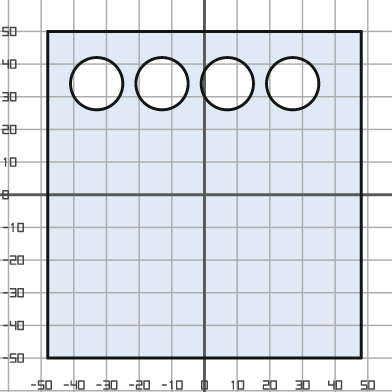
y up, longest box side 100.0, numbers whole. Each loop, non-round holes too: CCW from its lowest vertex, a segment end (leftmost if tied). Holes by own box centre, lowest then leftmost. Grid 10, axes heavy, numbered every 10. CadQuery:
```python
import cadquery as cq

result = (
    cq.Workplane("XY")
    .moveTo(-48.0, -50.0)
    .lineTo(48.0, -50.0)
    .lineTo(48.0, 50.0)
    .lineTo(-48.0, 50.0)
    .close()
    .moveTo(-33.0, 34.0)
    .circle(8.0)
    .moveTo(-13.0, 34.0)
    .circle(8.0)
    .moveTo(7.0, 34.0)
    .circle(8.0)
    .moveTo(27.0, 34.0)
    .circle(8.0)
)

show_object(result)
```